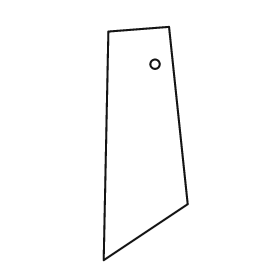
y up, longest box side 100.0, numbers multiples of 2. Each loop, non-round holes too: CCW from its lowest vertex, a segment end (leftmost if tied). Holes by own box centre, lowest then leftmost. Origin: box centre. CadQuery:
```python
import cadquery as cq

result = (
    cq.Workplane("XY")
    .moveTo(-18.0, -50.0)
    .lineTo(18.0, -26.0)
    .lineTo(10.0, 50.0)
    .lineTo(-16.0, 48.0)
    .close()
    .moveTo(4.0, 34.0)
    .circle(2.0)
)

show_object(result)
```